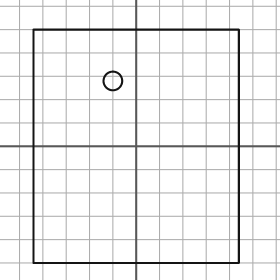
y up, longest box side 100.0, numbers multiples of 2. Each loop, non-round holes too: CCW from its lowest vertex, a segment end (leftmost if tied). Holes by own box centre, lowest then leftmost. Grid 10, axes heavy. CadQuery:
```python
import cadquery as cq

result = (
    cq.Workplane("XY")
    .moveTo(-44.0, -50.0)
    .lineTo(44.0, -50.0)
    .lineTo(44.0, 50.0)
    .lineTo(-44.0, 50.0)
    .close()
    .moveTo(-10.0, 28.0)
    .circle(4.0)
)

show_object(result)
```